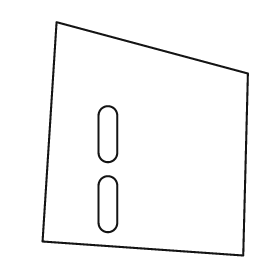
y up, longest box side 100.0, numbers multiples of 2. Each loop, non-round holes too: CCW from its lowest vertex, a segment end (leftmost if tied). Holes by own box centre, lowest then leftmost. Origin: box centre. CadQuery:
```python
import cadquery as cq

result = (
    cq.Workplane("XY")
    .moveTo(42.0, -50.0)
    .lineTo(44.0, 28.0)
    .lineTo(-38.0, 50.0)
    .lineTo(-44.0, -44.0)
    .close()
    .moveTo(-20.0, -36.0)
    .threePointArc((-16.0, -40.0), (-12.0, -36.0))
    .lineTo(-12.0, -20.0)
    .threePointArc((-16.0, -16.0), (-20.0, -20.0))
    .close()
    .moveTo(-20.0, -6.0)
    .threePointArc((-16.0, -10.0), (-12.0, -6.0))
    .lineTo(-12.0, 10.0)
    .threePointArc((-16.0, 14.0), (-20.0, 10.0))
    .close()
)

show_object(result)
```